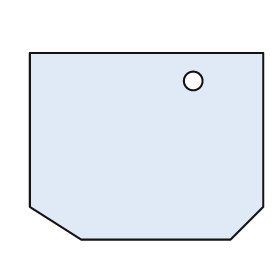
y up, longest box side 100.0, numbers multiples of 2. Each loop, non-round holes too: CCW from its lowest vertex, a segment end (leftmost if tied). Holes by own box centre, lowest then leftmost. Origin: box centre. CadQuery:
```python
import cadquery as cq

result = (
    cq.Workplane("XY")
    .moveTo(-28.0, -40.0)
    .lineTo(36.0, -40.0)
    .lineTo(50.0, -26.0)
    .lineTo(50.0, 40.0)
    .lineTo(-50.0, 40.0)
    .lineTo(-50.0, -26.0)
    .close()
    .moveTo(20.0, 28.0)
    .circle(4.0)
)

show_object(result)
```